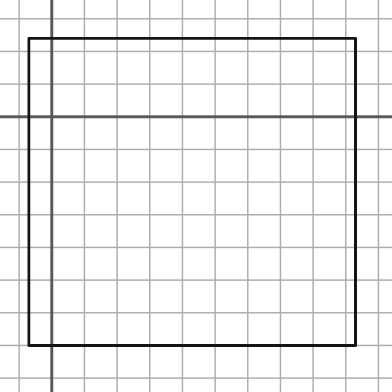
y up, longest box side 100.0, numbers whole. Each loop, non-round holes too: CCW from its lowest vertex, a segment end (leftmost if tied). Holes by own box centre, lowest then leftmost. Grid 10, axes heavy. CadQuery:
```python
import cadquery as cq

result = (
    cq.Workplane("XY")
    .moveTo(-7.0, -70.0)
    .lineTo(93.0, -70.0)
    .lineTo(93.0, 24.0)
    .lineTo(-7.0, 24.0)
    .close()
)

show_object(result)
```